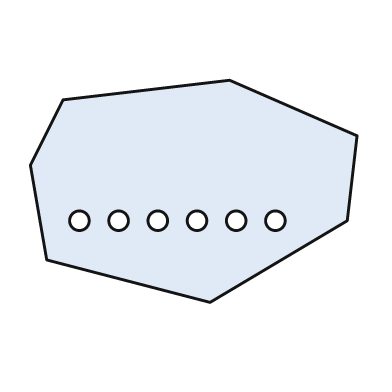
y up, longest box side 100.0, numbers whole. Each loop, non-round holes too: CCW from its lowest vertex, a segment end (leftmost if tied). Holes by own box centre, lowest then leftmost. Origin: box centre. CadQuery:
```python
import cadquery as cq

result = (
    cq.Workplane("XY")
    .moveTo(5.0, -34.0)
    .lineTo(47.0, -9.0)
    .lineTo(50.0, 17.0)
    .lineTo(11.0, 34.0)
    .lineTo(-40.0, 28.0)
    .lineTo(-50.0, 8.0)
    .lineTo(-45.0, -21.0)
    .close()
    .moveTo(-35.0, -9.0)
    .circle(3.0)
    .moveTo(-23.0, -9.0)
    .circle(3.0)
    .moveTo(-11.0, -9.0)
    .circle(3.0)
    .moveTo(1.0, -9.0)
    .circle(3.0)
    .moveTo(13.0, -9.0)
    .circle(3.0)
    .moveTo(25.0, -9.0)
    .circle(3.0)
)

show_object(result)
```